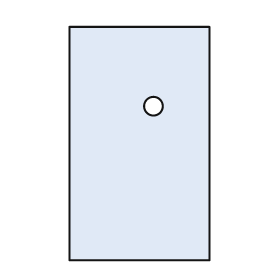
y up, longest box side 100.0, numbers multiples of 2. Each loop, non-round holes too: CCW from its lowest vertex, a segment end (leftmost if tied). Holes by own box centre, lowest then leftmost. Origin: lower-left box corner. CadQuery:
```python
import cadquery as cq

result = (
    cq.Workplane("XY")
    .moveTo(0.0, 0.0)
    .lineTo(60.0, 0.0)
    .lineTo(60.0, 100.0)
    .lineTo(0.0, 100.0)
    .close()
    .moveTo(36.0, 66.0)
    .circle(4.0)
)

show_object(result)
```